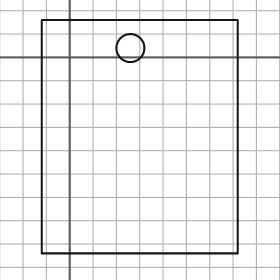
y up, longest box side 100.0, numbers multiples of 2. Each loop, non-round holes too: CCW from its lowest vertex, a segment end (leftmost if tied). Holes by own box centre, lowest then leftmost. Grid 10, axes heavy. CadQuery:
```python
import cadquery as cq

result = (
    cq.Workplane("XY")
    .moveTo(-12.0, -84.0)
    .lineTo(72.0, -84.0)
    .lineTo(72.0, 16.0)
    .lineTo(-12.0, 16.0)
    .close()
    .moveTo(26.0, 4.0)
    .circle(6.0)
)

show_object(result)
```